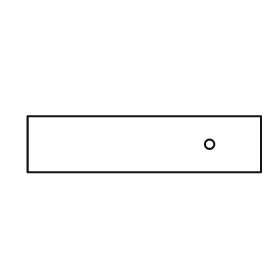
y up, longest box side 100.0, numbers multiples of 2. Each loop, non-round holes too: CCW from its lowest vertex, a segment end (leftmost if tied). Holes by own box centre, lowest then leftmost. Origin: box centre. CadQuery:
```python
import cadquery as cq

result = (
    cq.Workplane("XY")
    .moveTo(-50.0, -12.0)
    .lineTo(50.0, -12.0)
    .lineTo(50.0, 12.0)
    .lineTo(-50.0, 12.0)
    .close()
    .moveTo(28.0, 0.0)
    .circle(2.0)
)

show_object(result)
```